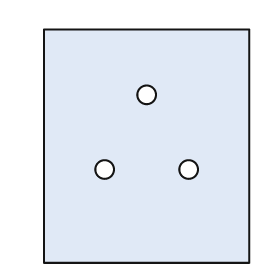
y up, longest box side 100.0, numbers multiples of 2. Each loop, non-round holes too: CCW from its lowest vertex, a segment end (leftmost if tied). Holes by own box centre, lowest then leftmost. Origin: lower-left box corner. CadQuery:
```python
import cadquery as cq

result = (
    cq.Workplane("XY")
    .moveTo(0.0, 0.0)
    .lineTo(88.0, 0.0)
    .lineTo(88.0, 100.0)
    .lineTo(0.0, 100.0)
    .close()
    .moveTo(26.0, 40.0)
    .circle(4.0)
    .moveTo(62.0, 40.0)
    .circle(4.0)
    .moveTo(44.0, 72.0)
    .circle(4.0)
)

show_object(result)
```